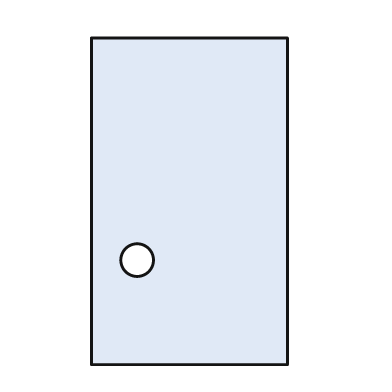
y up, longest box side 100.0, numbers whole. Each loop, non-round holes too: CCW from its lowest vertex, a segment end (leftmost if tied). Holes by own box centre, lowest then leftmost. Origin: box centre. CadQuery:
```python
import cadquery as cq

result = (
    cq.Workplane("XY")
    .moveTo(-30.0, -50.0)
    .lineTo(30.0, -50.0)
    .lineTo(30.0, 50.0)
    .lineTo(-30.0, 50.0)
    .close()
    .moveTo(-16.0, -18.0)
    .circle(5.0)
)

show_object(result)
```